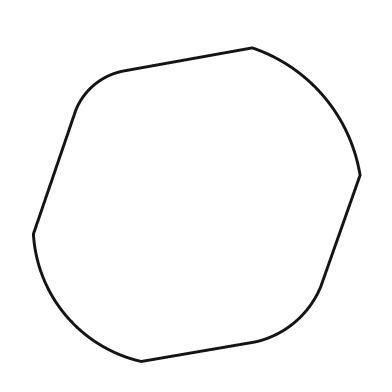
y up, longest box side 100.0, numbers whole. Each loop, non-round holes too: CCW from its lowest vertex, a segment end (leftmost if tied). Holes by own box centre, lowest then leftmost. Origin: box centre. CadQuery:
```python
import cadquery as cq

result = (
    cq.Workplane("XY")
    .moveTo(-17.0, -48.0)
    .lineTo(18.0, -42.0)
    .threePointArc((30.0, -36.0), (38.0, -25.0))
    .lineTo(50.0, 9.0)
    .threePointArc((39.0, 33.0), (17.0, 48.0))
    .lineTo(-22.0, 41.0)
    .threePointArc((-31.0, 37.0), (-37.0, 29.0))
    .lineTo(-50.0, -9.0)
    .threePointArc((-40.0, -34.0), (-17.0, -48.0))
    .close()
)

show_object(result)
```